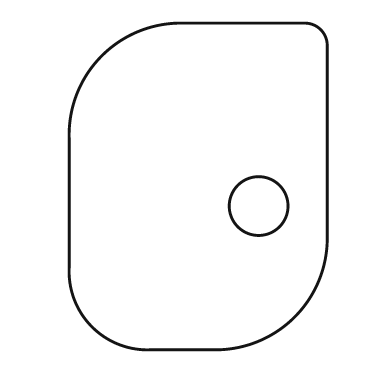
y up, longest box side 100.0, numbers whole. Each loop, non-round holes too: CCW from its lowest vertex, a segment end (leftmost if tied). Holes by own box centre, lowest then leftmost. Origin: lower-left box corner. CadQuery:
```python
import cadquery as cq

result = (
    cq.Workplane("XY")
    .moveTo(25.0, 0.0)
    .lineTo(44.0, 0.0)
    .threePointArc((69.0, 10.0), (79.0, 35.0))
    .lineTo(79.0, 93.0)
    .threePointArc((77.0, 98.0), (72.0, 100.0))
    .lineTo(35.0, 100.0)
    .threePointArc((10.0, 90.0), (0.0, 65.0))
    .lineTo(0.0, 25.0)
    .threePointArc((7.0, 7.0), (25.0, 0.0))
    .close()
    .moveTo(58.0, 44.0)
    .circle(9.0)
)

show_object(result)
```